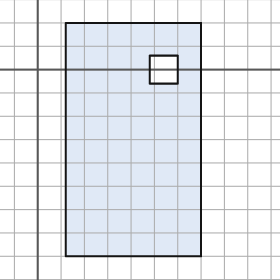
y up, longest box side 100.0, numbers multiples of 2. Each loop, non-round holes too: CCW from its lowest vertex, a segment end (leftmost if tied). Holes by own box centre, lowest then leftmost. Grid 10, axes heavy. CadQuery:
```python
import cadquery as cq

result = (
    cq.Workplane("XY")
    .moveTo(12.0, -80.0)
    .lineTo(70.0, -80.0)
    .lineTo(70.0, 20.0)
    .lineTo(12.0, 20.0)
    .close()
    .moveTo(48.0, -6.0)
    .lineTo(60.0, -6.0)
    .lineTo(60.0, 6.0)
    .lineTo(48.0, 6.0)
    .close()
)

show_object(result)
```